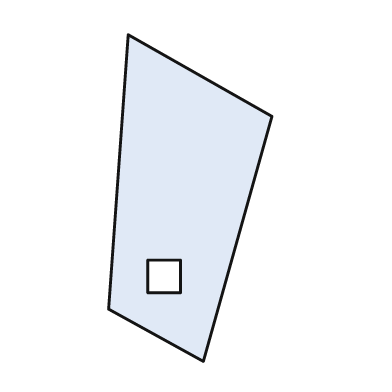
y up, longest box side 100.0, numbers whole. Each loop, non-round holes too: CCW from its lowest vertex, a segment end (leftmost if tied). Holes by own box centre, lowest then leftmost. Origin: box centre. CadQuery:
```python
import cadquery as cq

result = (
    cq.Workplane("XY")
    .moveTo(4.0, -50.0)
    .lineTo(25.0, 25.0)
    .lineTo(-19.0, 50.0)
    .lineTo(-25.0, -34.0)
    .close()
    .moveTo(-13.0, -29.0)
    .lineTo(-3.0, -29.0)
    .lineTo(-3.0, -19.0)
    .lineTo(-13.0, -19.0)
    .close()
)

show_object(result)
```